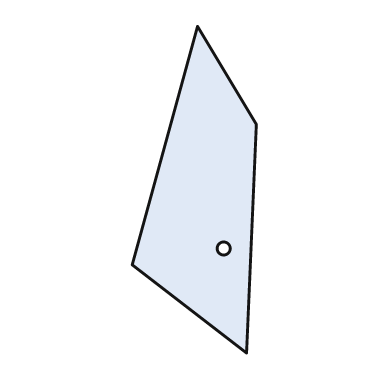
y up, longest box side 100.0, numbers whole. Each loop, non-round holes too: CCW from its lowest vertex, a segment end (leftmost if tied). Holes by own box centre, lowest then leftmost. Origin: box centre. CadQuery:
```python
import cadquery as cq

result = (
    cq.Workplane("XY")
    .moveTo(16.0, -50.0)
    .lineTo(19.0, 20.0)
    .lineTo(1.0, 50.0)
    .lineTo(-19.0, -23.0)
    .close()
    .moveTo(9.0, -18.0)
    .circle(2.0)
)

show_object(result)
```